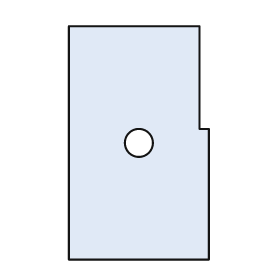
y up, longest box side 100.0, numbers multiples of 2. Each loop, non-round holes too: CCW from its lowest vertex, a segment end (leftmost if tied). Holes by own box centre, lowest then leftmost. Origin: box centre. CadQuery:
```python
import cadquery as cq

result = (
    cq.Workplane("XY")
    .moveTo(-30.0, -50.0)
    .lineTo(30.0, -50.0)
    .lineTo(30.0, 6.0)
    .lineTo(26.0, 6.0)
    .lineTo(26.0, 50.0)
    .lineTo(-30.0, 50.0)
    .close()
    .moveTo(0.0, 0.0)
    .circle(6.0)
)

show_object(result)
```